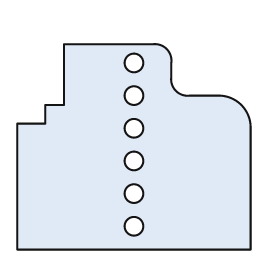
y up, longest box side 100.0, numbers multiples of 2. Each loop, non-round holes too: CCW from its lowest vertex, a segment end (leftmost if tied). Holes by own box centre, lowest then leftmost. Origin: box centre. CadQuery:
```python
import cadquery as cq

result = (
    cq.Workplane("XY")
    .moveTo(-50.0, -44.0)
    .lineTo(50.0, -44.0)
    .lineTo(50.0, 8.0)
    .threePointArc((46.0, 18.0), (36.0, 22.0))
    .lineTo(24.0, 22.0)
    .threePointArc((18.0, 24.0), (16.0, 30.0))
    .lineTo(16.0, 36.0)
    .threePointArc((14.0, 42.0), (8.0, 44.0))
    .lineTo(-30.0, 44.0)
    .lineTo(-30.0, 18.0)
    .lineTo(-38.0, 18.0)
    .lineTo(-38.0, 10.0)
    .lineTo(-50.0, 10.0)
    .close()
    .moveTo(0.0, -34.0)
    .circle(4.0)
    .moveTo(0.0, -20.0)
    .circle(4.0)
    .moveTo(0.0, -6.0)
    .circle(4.0)
    .moveTo(0.0, 8.0)
    .circle(4.0)
    .moveTo(0.0, 22.0)
    .circle(4.0)
    .moveTo(0.0, 36.0)
    .circle(4.0)
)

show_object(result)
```